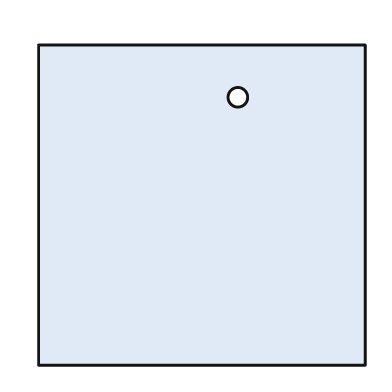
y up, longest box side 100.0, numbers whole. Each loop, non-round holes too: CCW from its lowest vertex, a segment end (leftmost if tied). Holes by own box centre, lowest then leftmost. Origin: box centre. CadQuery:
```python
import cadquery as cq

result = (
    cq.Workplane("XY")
    .moveTo(-50.0, -49.0)
    .lineTo(50.0, -49.0)
    .lineTo(50.0, 49.0)
    .lineTo(-50.0, 49.0)
    .close()
    .moveTo(11.0, 33.0)
    .circle(3.0)
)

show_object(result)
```